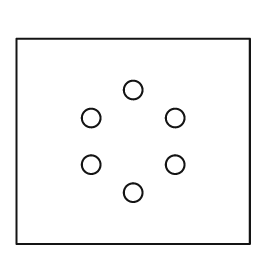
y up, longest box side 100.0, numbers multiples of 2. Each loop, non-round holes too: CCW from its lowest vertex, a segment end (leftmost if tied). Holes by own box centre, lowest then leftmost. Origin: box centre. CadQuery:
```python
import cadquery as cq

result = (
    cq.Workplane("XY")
    .moveTo(-50.0, -44.0)
    .lineTo(50.0, -44.0)
    .lineTo(50.0, 44.0)
    .lineTo(-50.0, 44.0)
    .close()
    .moveTo(0.0, -22.0)
    .circle(4.0)
    .moveTo(-18.0, -10.0)
    .circle(4.0)
    .moveTo(18.0, -10.0)
    .circle(4.0)
    .moveTo(-18.0, 10.0)
    .circle(4.0)
    .moveTo(18.0, 10.0)
    .circle(4.0)
    .moveTo(0.0, 22.0)
    .circle(4.0)
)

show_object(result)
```